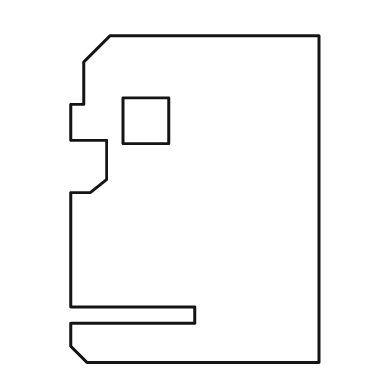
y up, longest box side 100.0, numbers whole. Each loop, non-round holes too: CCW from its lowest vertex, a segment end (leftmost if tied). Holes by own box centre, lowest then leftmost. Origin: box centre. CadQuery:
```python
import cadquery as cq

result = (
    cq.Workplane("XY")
    .moveTo(-33.0, -50.0)
    .lineTo(38.0, -50.0)
    .lineTo(38.0, 50.0)
    .lineTo(-26.0, 50.0)
    .lineTo(-34.0, 42.0)
    .lineTo(-34.0, 29.0)
    .lineTo(-38.0, 29.0)
    .lineTo(-38.0, 18.0)
    .lineTo(-27.0, 18.0)
    .lineTo(-27.0, 6.0)
    .lineTo(-32.0, 2.0)
    .lineTo(-38.0, 2.0)
    .lineTo(-38.0, -33.0)
    .lineTo(0.0, -33.0)
    .lineTo(0.0, -38.0)
    .lineTo(-38.0, -38.0)
    .lineTo(-38.0, -45.0)
    .close()
    .moveTo(-22.0, 17.0)
    .lineTo(-8.0, 17.0)
    .lineTo(-8.0, 31.0)
    .lineTo(-22.0, 31.0)
    .close()
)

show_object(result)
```